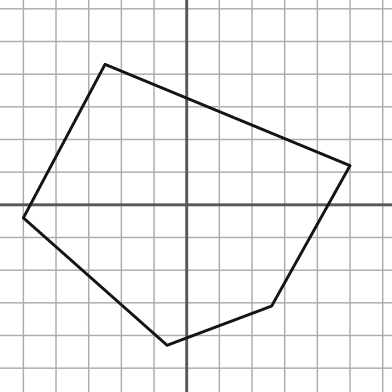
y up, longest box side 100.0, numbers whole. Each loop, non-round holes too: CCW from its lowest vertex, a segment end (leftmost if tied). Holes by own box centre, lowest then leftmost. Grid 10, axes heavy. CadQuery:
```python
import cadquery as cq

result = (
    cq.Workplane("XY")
    .moveTo(-6.0, -43.0)
    .lineTo(26.0, -31.0)
    .lineTo(50.0, 12.0)
    .lineTo(-25.0, 43.0)
    .lineTo(-50.0, -4.0)
    .close()
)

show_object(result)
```